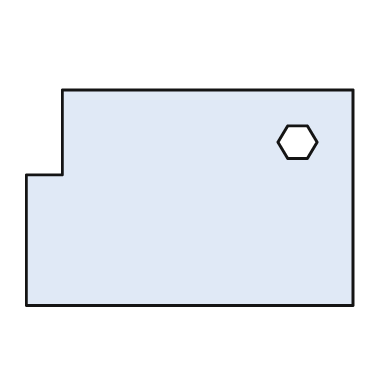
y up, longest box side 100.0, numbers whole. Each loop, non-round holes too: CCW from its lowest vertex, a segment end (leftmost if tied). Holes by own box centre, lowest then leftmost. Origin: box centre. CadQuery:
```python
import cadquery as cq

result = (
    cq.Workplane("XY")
    .moveTo(-50.0, -33.0)
    .lineTo(50.0, -33.0)
    .lineTo(50.0, 33.0)
    .lineTo(-39.0, 33.0)
    .lineTo(-39.0, 7.0)
    .lineTo(-50.0, 7.0)
    .close()
    .moveTo(30.0, 12.0)
    .lineTo(36.0, 12.0)
    .lineTo(39.0, 17.0)
    .lineTo(36.0, 22.0)
    .lineTo(30.0, 22.0)
    .lineTo(27.0, 17.0)
    .close()
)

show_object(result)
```